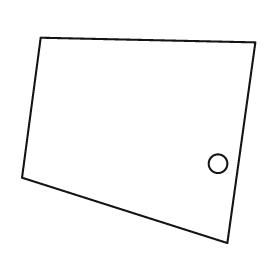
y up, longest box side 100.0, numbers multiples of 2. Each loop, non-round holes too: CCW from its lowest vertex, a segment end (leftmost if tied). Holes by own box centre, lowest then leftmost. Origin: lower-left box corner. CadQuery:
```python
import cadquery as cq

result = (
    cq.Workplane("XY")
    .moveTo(88.0, 0.0)
    .lineTo(100.0, 86.0)
    .lineTo(8.0, 88.0)
    .lineTo(0.0, 28.0)
    .close()
    .moveTo(84.0, 34.0)
    .circle(4.0)
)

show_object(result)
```